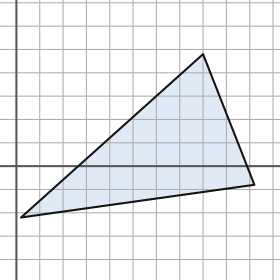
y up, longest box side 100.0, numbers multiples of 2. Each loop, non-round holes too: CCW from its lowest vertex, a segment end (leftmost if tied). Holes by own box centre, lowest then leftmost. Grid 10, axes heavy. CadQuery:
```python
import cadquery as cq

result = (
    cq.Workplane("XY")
    .moveTo(2.0, -22.0)
    .lineTo(102.0, -8.0)
    .lineTo(80.0, 48.0)
    .close()
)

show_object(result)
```